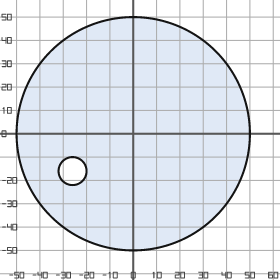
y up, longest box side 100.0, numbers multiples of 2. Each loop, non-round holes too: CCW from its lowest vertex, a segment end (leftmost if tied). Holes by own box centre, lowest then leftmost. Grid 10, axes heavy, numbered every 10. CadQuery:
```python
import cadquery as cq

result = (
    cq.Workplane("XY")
    .moveTo(0.0, 0.0)
    .circle(50.0)
    .moveTo(-26.0, -16.0)
    .circle(6.0)
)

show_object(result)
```